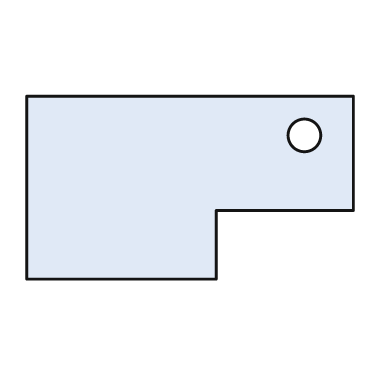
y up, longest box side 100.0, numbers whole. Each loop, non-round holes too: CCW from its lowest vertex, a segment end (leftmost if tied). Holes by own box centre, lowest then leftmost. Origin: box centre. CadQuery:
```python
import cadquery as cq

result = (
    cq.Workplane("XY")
    .moveTo(-50.0, -28.0)
    .lineTo(8.0, -28.0)
    .lineTo(8.0, -7.0)
    .lineTo(50.0, -7.0)
    .lineTo(50.0, 28.0)
    .lineTo(-50.0, 28.0)
    .close()
    .moveTo(35.0, 16.0)
    .circle(5.0)
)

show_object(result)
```